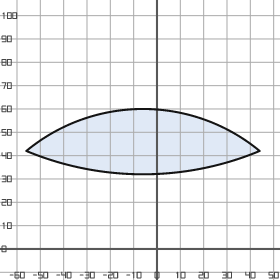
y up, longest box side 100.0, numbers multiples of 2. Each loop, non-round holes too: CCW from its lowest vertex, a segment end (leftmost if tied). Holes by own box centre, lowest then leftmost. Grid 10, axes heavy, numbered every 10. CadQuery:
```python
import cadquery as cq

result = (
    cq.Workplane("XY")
    .moveTo(-56.0, 42.0)
    .threePointArc((-6.0, 32.0), (44.0, 42.0))
    .threePointArc((-6.0, 60.0), (-56.0, 42.0))
    .close()
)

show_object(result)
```